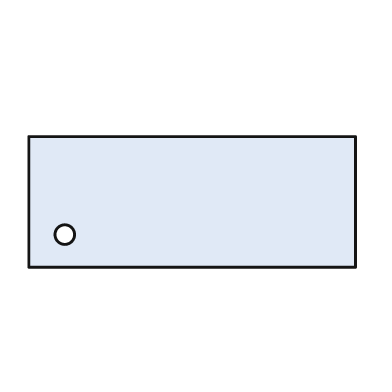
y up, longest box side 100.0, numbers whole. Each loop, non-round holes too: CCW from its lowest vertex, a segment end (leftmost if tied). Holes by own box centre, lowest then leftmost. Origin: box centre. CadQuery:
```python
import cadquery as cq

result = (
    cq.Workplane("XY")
    .moveTo(-50.0, -20.0)
    .lineTo(50.0, -20.0)
    .lineTo(50.0, 20.0)
    .lineTo(-50.0, 20.0)
    .close()
    .moveTo(-39.0, -10.0)
    .circle(3.0)
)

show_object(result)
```